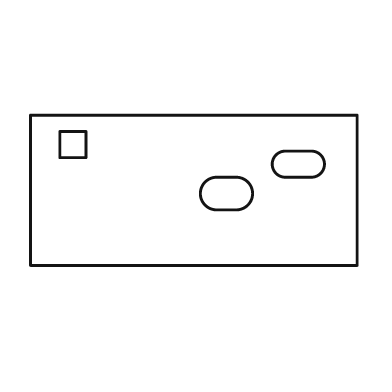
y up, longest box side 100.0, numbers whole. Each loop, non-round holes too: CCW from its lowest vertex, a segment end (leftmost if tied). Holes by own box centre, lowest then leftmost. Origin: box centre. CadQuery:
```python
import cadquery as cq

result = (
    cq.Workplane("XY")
    .moveTo(-50.0, -23.0)
    .lineTo(50.0, -23.0)
    .lineTo(50.0, 23.0)
    .lineTo(-50.0, 23.0)
    .close()
    .moveTo(7.0, -6.0)
    .lineTo(13.0, -6.0)
    .threePointArc((18.0, -1.0), (13.0, 4.0))
    .lineTo(7.0, 4.0)
    .threePointArc((2.0, -1.0), (7.0, -6.0))
    .close()
    .moveTo(28.0, 4.0)
    .lineTo(36.0, 4.0)
    .threePointArc((40.0, 8.0), (36.0, 12.0))
    .lineTo(28.0, 12.0)
    .threePointArc((24.0, 8.0), (28.0, 4.0))
    .close()
    .moveTo(-41.0, 10.0)
    .lineTo(-33.0, 10.0)
    .lineTo(-33.0, 18.0)
    .lineTo(-41.0, 18.0)
    .close()
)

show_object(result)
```